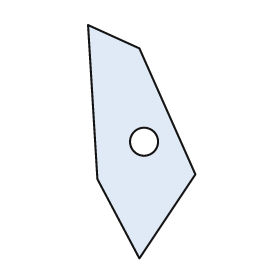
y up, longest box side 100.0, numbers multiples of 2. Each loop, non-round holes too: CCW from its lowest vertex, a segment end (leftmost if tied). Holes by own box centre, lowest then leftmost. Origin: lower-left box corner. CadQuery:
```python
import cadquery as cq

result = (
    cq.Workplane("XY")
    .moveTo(22.0, 0.0)
    .lineTo(46.0, 36.0)
    .lineTo(22.0, 90.0)
    .lineTo(0.0, 100.0)
    .lineTo(4.0, 34.0)
    .close()
    .moveTo(24.0, 50.0)
    .circle(6.0)
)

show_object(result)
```